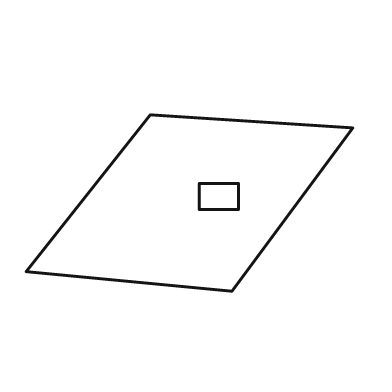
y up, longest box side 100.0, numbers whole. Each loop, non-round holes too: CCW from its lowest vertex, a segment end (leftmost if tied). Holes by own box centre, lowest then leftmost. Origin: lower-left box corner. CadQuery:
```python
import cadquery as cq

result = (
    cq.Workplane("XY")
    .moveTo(63.0, 0.0)
    .lineTo(100.0, 50.0)
    .lineTo(38.0, 54.0)
    .lineTo(0.0, 6.0)
    .close()
    .moveTo(53.0, 25.0)
    .lineTo(65.0, 25.0)
    .lineTo(65.0, 33.0)
    .lineTo(53.0, 33.0)
    .close()
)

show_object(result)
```